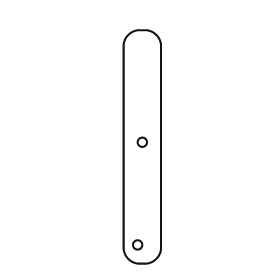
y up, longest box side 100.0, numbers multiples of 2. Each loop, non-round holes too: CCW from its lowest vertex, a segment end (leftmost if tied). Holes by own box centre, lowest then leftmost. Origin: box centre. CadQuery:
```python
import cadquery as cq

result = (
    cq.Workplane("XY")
    .moveTo(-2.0, -50.0)
    .lineTo(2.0, -50.0)
    .threePointArc((6.0, -48.0), (8.0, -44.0))
    .lineTo(8.0, 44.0)
    .threePointArc((6.0, 48.0), (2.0, 50.0))
    .lineTo(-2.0, 50.0)
    .threePointArc((-6.0, 48.0), (-8.0, 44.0))
    .lineTo(-8.0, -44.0)
    .threePointArc((-6.0, -48.0), (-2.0, -50.0))
    .close()
    .moveTo(-2.0, -42.0)
    .circle(2.0)
    .moveTo(0.0, 2.0)
    .circle(2.0)
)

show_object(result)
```